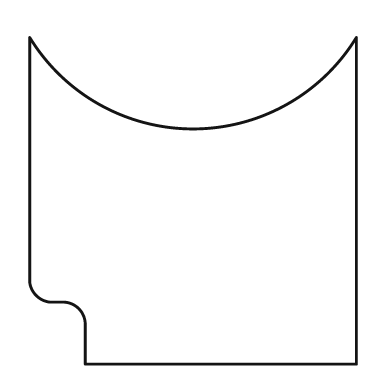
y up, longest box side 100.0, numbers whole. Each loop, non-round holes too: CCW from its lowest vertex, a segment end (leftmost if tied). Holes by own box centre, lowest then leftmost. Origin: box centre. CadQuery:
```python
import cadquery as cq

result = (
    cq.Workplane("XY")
    .moveTo(-33.0, -50.0)
    .lineTo(50.0, -50.0)
    .lineTo(50.0, 50.0)
    .threePointArc((0.0, 22.0), (-50.0, 50.0))
    .lineTo(-50.0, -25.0)
    .threePointArc((-48.0, -29.0), (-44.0, -31.0))
    .lineTo(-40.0, -31.0)
    .threePointArc((-35.0, -33.0), (-33.0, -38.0))
    .close()
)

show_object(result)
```